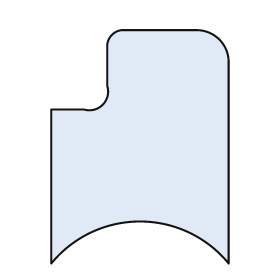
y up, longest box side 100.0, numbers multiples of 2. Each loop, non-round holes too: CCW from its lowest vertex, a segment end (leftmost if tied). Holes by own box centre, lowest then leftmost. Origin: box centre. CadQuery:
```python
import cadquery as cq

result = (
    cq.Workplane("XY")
    .moveTo(-38.0, -50.0)
    .threePointArc((0.0, -32.0), (38.0, -50.0))
    .lineTo(38.0, 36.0)
    .threePointArc((34.0, 46.0), (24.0, 50.0))
    .lineTo(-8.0, 50.0)
    .threePointArc((-12.0, 48.0), (-14.0, 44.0))
    .lineTo(-14.0, 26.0)
    .threePointArc((-16.0, 18.0), (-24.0, 16.0))
    .lineTo(-38.0, 16.0)
    .close()
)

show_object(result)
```